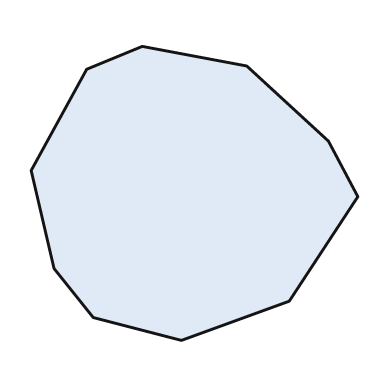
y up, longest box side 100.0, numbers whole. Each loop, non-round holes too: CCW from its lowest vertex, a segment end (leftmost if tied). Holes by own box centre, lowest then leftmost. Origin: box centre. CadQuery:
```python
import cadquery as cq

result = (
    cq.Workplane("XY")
    .moveTo(-4.0, -45.0)
    .lineTo(29.0, -33.0)
    .lineTo(50.0, -1.0)
    .lineTo(41.0, 16.0)
    .lineTo(16.0, 39.0)
    .lineTo(-16.0, 45.0)
    .lineTo(-33.0, 38.0)
    .lineTo(-50.0, 7.0)
    .lineTo(-43.0, -23.0)
    .lineTo(-31.0, -38.0)
    .close()
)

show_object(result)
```